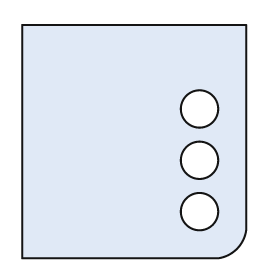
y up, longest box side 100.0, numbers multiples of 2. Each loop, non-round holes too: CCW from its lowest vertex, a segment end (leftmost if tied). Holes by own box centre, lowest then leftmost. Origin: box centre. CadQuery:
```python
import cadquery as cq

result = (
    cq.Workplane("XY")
    .moveTo(-48.0, -50.0)
    .lineTo(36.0, -50.0)
    .threePointArc((44.0, -46.0), (48.0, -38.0))
    .lineTo(48.0, 50.0)
    .lineTo(-48.0, 50.0)
    .close()
    .moveTo(28.0, -30.0)
    .circle(8.0)
    .moveTo(28.0, -8.0)
    .circle(8.0)
    .moveTo(28.0, 14.0)
    .circle(8.0)
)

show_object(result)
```